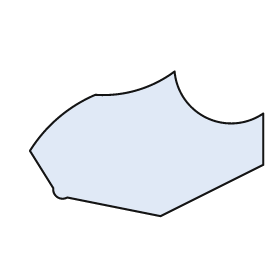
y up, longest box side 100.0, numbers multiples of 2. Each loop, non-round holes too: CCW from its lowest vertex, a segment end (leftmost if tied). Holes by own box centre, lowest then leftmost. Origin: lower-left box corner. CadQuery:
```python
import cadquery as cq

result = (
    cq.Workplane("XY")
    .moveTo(56.0, 0.0)
    .lineTo(100.0, 22.0)
    .lineTo(100.0, 44.0)
    .threePointArc((76.0, 42.0), (62.0, 62.0))
    .threePointArc((46.0, 54.0), (28.0, 52.0))
    .threePointArc((12.0, 42.0), (0.0, 28.0))
    .lineTo(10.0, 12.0)
    .threePointArc((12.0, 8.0), (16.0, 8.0))
    .close()
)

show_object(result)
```